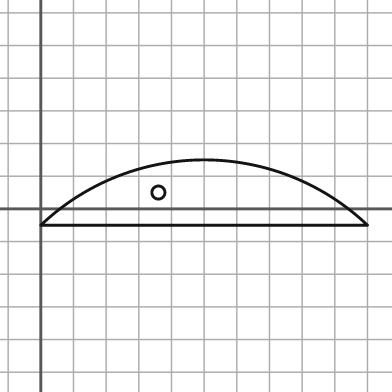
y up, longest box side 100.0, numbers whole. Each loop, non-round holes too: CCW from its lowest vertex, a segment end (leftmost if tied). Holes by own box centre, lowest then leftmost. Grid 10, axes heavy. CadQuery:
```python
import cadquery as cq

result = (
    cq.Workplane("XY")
    .moveTo(0.0, -5.0)
    .lineTo(100.0, -5.0)
    .threePointArc((50.0, 15.0), (0.0, -5.0))
    .close()
    .moveTo(36.0, 5.0)
    .circle(2.0)
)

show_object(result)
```